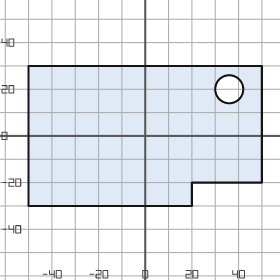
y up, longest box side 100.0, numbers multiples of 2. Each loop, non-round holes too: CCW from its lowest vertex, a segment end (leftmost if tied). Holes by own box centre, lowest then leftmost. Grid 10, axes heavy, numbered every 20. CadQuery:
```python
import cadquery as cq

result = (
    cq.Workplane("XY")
    .moveTo(-50.0, -30.0)
    .lineTo(20.0, -30.0)
    .lineTo(20.0, -20.0)
    .lineTo(50.0, -20.0)
    .lineTo(50.0, 30.0)
    .lineTo(-50.0, 30.0)
    .close()
    .moveTo(36.0, 20.0)
    .circle(6.0)
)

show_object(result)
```